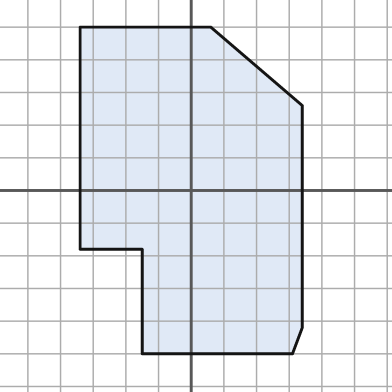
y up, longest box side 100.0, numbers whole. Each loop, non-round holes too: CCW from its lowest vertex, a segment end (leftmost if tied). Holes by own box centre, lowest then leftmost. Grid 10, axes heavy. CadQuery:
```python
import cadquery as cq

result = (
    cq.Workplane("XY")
    .moveTo(-15.0, -50.0)
    .lineTo(31.0, -50.0)
    .lineTo(34.0, -42.0)
    .lineTo(34.0, 26.0)
    .lineTo(6.0, 50.0)
    .lineTo(-34.0, 50.0)
    .lineTo(-34.0, -18.0)
    .lineTo(-15.0, -18.0)
    .close()
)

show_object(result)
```